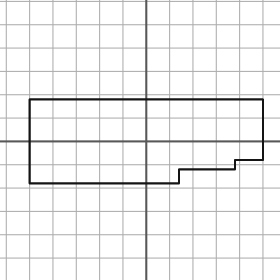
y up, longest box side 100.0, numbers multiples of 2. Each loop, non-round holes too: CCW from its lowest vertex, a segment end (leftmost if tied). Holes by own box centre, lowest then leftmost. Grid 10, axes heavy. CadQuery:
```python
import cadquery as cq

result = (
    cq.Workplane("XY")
    .moveTo(-50.0, -18.0)
    .lineTo(14.0, -18.0)
    .lineTo(14.0, -12.0)
    .lineTo(38.0, -12.0)
    .lineTo(38.0, -8.0)
    .lineTo(50.0, -8.0)
    .lineTo(50.0, 18.0)
    .lineTo(-50.0, 18.0)
    .close()
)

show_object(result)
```